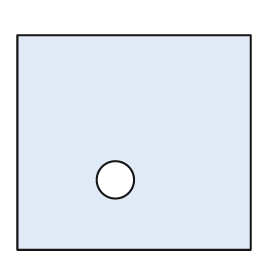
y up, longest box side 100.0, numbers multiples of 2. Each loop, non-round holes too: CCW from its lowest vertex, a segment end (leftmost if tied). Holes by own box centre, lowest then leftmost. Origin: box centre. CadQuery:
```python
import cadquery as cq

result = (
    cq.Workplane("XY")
    .moveTo(-50.0, -46.0)
    .lineTo(50.0, -46.0)
    .lineTo(50.0, 46.0)
    .lineTo(-50.0, 46.0)
    .close()
    .moveTo(-8.0, -16.0)
    .circle(8.0)
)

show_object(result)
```